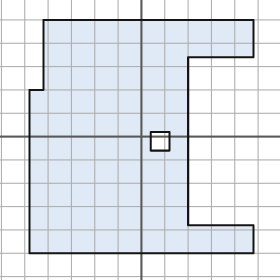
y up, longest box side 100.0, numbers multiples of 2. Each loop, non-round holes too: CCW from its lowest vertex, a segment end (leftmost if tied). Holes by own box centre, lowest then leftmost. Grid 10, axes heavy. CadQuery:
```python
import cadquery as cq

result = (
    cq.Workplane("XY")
    .moveTo(-48.0, -50.0)
    .lineTo(48.0, -50.0)
    .lineTo(48.0, -38.0)
    .lineTo(20.0, -38.0)
    .lineTo(20.0, 34.0)
    .lineTo(48.0, 34.0)
    .lineTo(48.0, 50.0)
    .lineTo(-42.0, 50.0)
    .lineTo(-42.0, 20.0)
    .lineTo(-48.0, 20.0)
    .close()
    .moveTo(4.0, -6.0)
    .lineTo(12.0, -6.0)
    .lineTo(12.0, 2.0)
    .lineTo(4.0, 2.0)
    .close()
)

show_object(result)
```